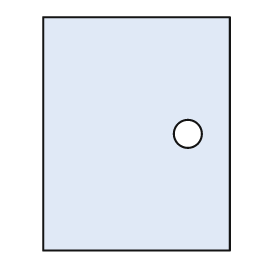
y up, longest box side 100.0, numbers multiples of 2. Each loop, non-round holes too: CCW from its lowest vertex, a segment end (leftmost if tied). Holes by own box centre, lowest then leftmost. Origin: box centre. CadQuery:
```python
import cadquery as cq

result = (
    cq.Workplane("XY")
    .moveTo(-40.0, -50.0)
    .lineTo(40.0, -50.0)
    .lineTo(40.0, 50.0)
    .lineTo(-40.0, 50.0)
    .close()
    .moveTo(22.0, 0.0)
    .circle(6.0)
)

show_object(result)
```